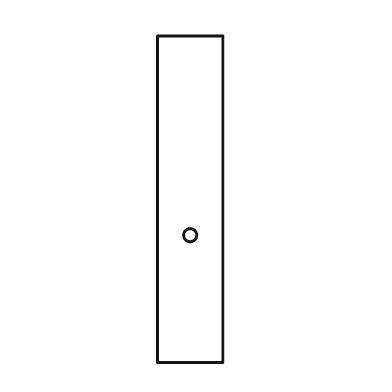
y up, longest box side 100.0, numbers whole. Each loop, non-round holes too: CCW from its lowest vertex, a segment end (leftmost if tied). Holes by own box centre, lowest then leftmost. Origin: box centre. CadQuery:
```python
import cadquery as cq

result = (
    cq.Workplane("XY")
    .moveTo(-10.0, -50.0)
    .lineTo(10.0, -50.0)
    .lineTo(10.0, 50.0)
    .lineTo(-10.0, 50.0)
    .close()
    .moveTo(0.0, -11.0)
    .circle(2.0)
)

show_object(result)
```